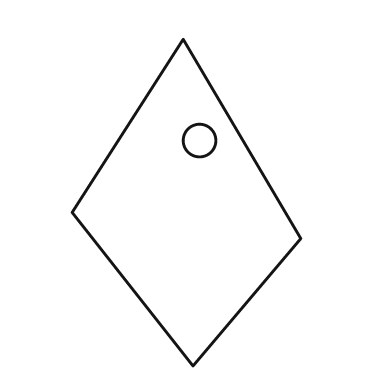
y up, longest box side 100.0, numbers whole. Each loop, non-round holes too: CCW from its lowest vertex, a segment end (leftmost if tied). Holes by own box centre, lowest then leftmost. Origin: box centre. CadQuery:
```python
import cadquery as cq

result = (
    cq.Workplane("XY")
    .moveTo(2.0, -50.0)
    .lineTo(35.0, -11.0)
    .lineTo(-1.0, 50.0)
    .lineTo(-35.0, -3.0)
    .close()
    .moveTo(4.0, 19.0)
    .circle(5.0)
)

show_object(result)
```